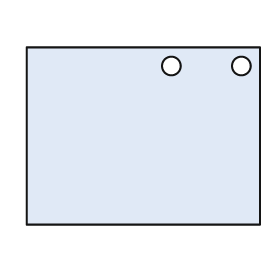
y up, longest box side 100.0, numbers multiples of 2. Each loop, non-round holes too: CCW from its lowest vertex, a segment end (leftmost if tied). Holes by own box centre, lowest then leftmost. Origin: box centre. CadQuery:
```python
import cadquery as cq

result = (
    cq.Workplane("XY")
    .moveTo(-50.0, -38.0)
    .lineTo(50.0, -38.0)
    .lineTo(50.0, 38.0)
    .lineTo(-50.0, 38.0)
    .close()
    .moveTo(12.0, 30.0)
    .circle(4.0)
    .moveTo(42.0, 30.0)
    .circle(4.0)
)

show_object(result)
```